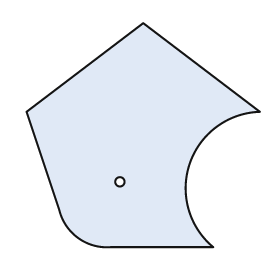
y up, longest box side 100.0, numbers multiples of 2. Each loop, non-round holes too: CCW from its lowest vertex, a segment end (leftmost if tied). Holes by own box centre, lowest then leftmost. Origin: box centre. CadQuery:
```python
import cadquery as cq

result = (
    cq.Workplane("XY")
    .moveTo(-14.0, -48.0)
    .lineTo(30.0, -48.0)
    .threePointArc((20.0, -12.0), (50.0, 10.0))
    .lineTo(0.0, 48.0)
    .lineTo(-50.0, 10.0)
    .lineTo(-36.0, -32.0)
    .threePointArc((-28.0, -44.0), (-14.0, -48.0))
    .close()
    .moveTo(-10.0, -20.0)
    .circle(2.0)
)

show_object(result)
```